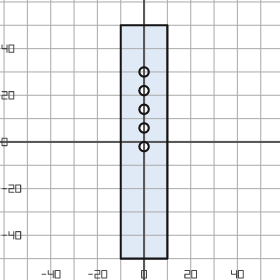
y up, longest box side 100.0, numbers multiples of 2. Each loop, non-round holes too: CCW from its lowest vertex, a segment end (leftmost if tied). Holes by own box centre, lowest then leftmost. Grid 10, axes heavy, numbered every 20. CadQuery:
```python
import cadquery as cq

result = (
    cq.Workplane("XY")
    .moveTo(-10.0, -50.0)
    .lineTo(10.0, -50.0)
    .lineTo(10.0, 50.0)
    .lineTo(-10.0, 50.0)
    .close()
    .moveTo(0.0, -2.0)
    .circle(2.0)
    .moveTo(0.0, 6.0)
    .circle(2.0)
    .moveTo(0.0, 14.0)
    .circle(2.0)
    .moveTo(0.0, 22.0)
    .circle(2.0)
    .moveTo(0.0, 30.0)
    .circle(2.0)
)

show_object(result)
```